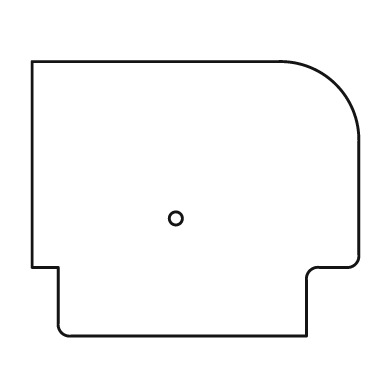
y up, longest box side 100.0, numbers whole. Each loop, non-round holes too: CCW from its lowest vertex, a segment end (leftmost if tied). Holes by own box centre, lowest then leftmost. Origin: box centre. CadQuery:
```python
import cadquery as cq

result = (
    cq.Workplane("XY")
    .moveTo(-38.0, -42.0)
    .lineTo(34.0, -42.0)
    .lineTo(34.0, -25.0)
    .threePointArc((35.0, -22.0), (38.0, -21.0))
    .lineTo(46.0, -21.0)
    .threePointArc((49.0, -20.0), (50.0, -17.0))
    .lineTo(50.0, 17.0)
    .threePointArc((43.0, 35.0), (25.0, 42.0))
    .lineTo(-50.0, 42.0)
    .lineTo(-50.0, -21.0)
    .lineTo(-42.0, -21.0)
    .lineTo(-42.0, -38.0)
    .threePointArc((-41.0, -41.0), (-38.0, -42.0))
    .close()
    .moveTo(-6.0, -6.0)
    .circle(2.0)
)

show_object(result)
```